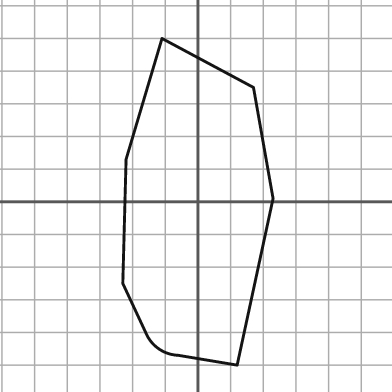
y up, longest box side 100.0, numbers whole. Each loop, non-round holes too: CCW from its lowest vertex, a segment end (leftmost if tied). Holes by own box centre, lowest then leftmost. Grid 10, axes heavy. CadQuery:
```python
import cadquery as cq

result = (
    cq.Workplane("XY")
    .moveTo(12.0, -50.0)
    .lineTo(23.0, 1.0)
    .lineTo(17.0, 35.0)
    .lineTo(-11.0, 50.0)
    .lineTo(-22.0, 13.0)
    .lineTo(-23.0, -25.0)
    .lineTo(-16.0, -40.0)
    .threePointArc((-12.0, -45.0), (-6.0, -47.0))
    .close()
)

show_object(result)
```